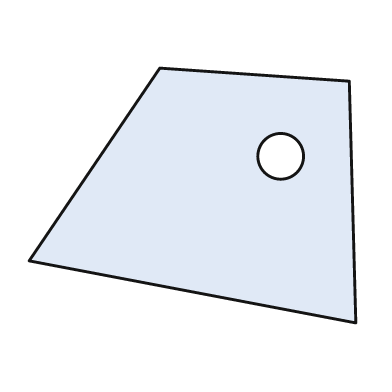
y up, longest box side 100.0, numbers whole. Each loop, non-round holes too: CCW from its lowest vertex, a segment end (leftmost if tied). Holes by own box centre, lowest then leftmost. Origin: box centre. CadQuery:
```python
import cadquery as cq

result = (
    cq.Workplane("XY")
    .moveTo(50.0, -39.0)
    .lineTo(48.0, 35.0)
    .lineTo(-10.0, 39.0)
    .lineTo(-50.0, -20.0)
    .close()
    .moveTo(27.0, 12.0)
    .circle(7.0)
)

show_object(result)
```